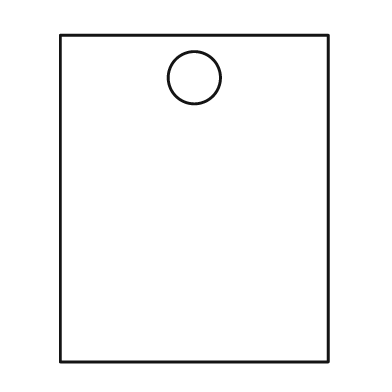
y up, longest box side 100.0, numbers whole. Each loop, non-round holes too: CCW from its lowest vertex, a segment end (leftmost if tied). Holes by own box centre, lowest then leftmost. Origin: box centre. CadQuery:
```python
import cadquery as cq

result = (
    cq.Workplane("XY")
    .moveTo(-41.0, -50.0)
    .lineTo(41.0, -50.0)
    .lineTo(41.0, 50.0)
    .lineTo(-41.0, 50.0)
    .close()
    .moveTo(0.0, 37.0)
    .circle(8.0)
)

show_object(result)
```